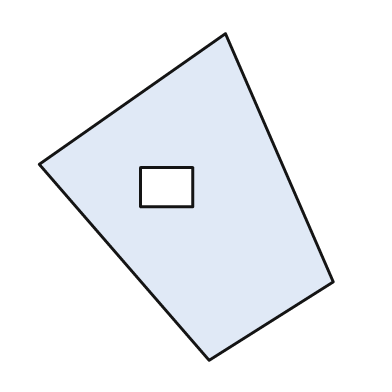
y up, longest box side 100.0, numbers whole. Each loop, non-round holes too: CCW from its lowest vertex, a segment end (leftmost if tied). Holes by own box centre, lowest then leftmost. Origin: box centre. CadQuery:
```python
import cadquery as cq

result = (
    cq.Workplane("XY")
    .moveTo(7.0, -50.0)
    .lineTo(45.0, -26.0)
    .lineTo(12.0, 50.0)
    .lineTo(-45.0, 10.0)
    .close()
    .moveTo(-14.0, -3.0)
    .lineTo(2.0, -3.0)
    .lineTo(2.0, 9.0)
    .lineTo(-14.0, 9.0)
    .close()
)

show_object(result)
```